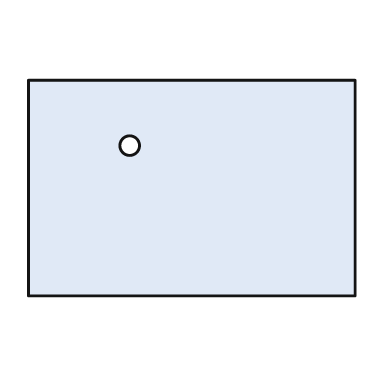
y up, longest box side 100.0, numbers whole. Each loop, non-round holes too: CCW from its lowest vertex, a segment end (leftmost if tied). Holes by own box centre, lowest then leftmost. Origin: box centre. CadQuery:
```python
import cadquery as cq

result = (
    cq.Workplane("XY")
    .moveTo(-50.0, -33.0)
    .lineTo(50.0, -33.0)
    .lineTo(50.0, 33.0)
    .lineTo(-50.0, 33.0)
    .close()
    .moveTo(-19.0, 13.0)
    .circle(3.0)
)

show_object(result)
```